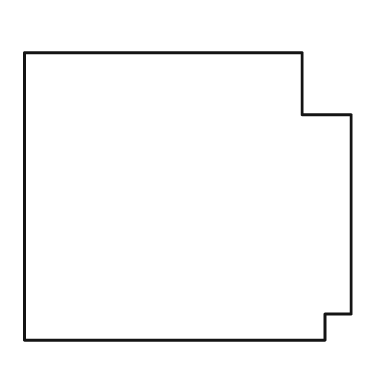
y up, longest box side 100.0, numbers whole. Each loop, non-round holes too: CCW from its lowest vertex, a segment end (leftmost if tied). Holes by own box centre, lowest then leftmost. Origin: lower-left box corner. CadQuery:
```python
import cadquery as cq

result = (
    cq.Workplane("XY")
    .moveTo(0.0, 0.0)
    .lineTo(92.0, 0.0)
    .lineTo(92.0, 8.0)
    .lineTo(100.0, 8.0)
    .lineTo(100.0, 69.0)
    .lineTo(85.0, 69.0)
    .lineTo(85.0, 88.0)
    .lineTo(0.0, 88.0)
    .close()
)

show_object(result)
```